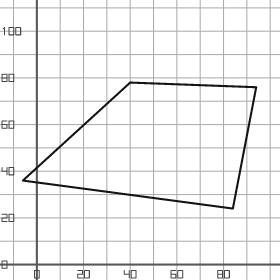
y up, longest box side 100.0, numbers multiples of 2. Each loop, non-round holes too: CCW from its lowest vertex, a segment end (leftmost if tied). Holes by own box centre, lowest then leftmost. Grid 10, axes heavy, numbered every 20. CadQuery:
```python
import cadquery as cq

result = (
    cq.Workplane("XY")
    .moveTo(84.0, 24.0)
    .lineTo(94.0, 76.0)
    .lineTo(40.0, 78.0)
    .lineTo(-6.0, 36.0)
    .close()
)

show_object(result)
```